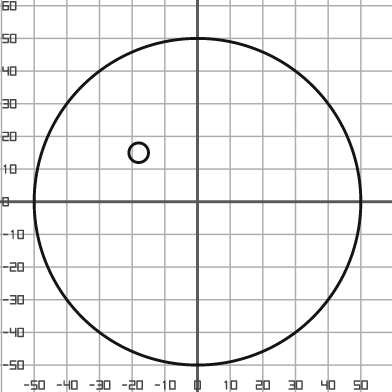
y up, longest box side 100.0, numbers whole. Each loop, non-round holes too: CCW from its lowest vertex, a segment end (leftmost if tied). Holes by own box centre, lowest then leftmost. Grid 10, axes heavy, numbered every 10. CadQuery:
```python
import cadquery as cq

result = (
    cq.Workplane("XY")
    .moveTo(0.0, 0.0)
    .circle(50.0)
    .moveTo(-18.0, 15.0)
    .circle(3.0)
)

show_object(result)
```